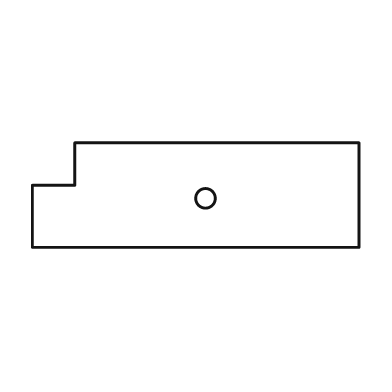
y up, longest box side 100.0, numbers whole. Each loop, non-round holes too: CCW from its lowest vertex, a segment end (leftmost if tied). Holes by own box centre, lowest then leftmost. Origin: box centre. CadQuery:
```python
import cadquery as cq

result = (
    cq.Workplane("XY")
    .moveTo(-50.0, -16.0)
    .lineTo(50.0, -16.0)
    .lineTo(50.0, 16.0)
    .lineTo(-37.0, 16.0)
    .lineTo(-37.0, 3.0)
    .lineTo(-50.0, 3.0)
    .close()
    .moveTo(3.0, -1.0)
    .circle(3.0)
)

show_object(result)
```